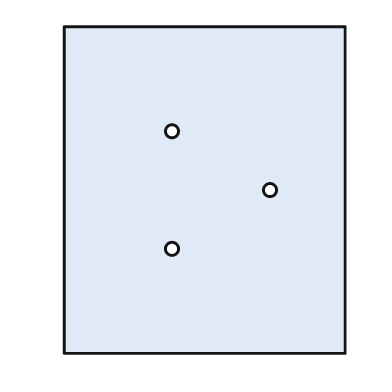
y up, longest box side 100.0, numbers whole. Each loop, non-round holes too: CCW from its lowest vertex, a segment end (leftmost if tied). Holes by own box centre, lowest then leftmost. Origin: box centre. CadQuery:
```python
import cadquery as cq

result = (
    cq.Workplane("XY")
    .moveTo(-43.0, -50.0)
    .lineTo(43.0, -50.0)
    .lineTo(43.0, 50.0)
    .lineTo(-43.0, 50.0)
    .close()
    .moveTo(-10.0, -18.0)
    .circle(2.0)
    .moveTo(20.0, 0.0)
    .circle(2.0)
    .moveTo(-10.0, 18.0)
    .circle(2.0)
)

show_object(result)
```